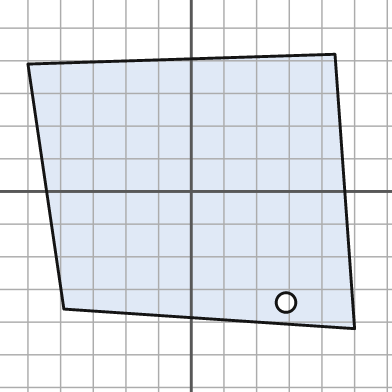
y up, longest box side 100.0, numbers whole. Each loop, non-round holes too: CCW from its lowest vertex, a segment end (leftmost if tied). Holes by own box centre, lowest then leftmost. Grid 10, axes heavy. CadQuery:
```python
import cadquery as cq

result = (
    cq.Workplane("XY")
    .moveTo(50.0, -42.0)
    .lineTo(44.0, 42.0)
    .lineTo(-50.0, 39.0)
    .lineTo(-39.0, -36.0)
    .close()
    .moveTo(29.0, -34.0)
    .circle(3.0)
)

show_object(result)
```